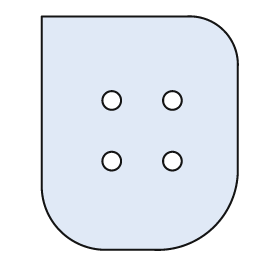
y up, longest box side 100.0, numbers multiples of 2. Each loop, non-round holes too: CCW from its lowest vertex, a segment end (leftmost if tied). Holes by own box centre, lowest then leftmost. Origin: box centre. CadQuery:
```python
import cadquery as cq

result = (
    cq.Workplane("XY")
    .moveTo(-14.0, -50.0)
    .lineTo(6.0, -50.0)
    .threePointArc((32.0, -40.0), (42.0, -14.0))
    .lineTo(42.0, 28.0)
    .threePointArc((36.0, 44.0), (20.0, 50.0))
    .lineTo(-42.0, 50.0)
    .lineTo(-42.0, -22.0)
    .threePointArc((-34.0, -42.0), (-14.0, -50.0))
    .close()
    .moveTo(-12.0, -12.0)
    .circle(4.0)
    .moveTo(14.0, -12.0)
    .circle(4.0)
    .moveTo(-12.0, 14.0)
    .circle(4.0)
    .moveTo(14.0, 14.0)
    .circle(4.0)
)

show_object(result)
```